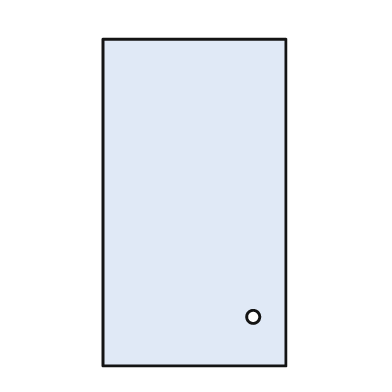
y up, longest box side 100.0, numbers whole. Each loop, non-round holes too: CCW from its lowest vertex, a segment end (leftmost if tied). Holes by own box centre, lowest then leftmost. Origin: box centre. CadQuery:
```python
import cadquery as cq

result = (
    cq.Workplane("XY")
    .moveTo(-28.0, -50.0)
    .lineTo(28.0, -50.0)
    .lineTo(28.0, 50.0)
    .lineTo(-28.0, 50.0)
    .close()
    .moveTo(18.0, -35.0)
    .circle(2.0)
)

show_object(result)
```